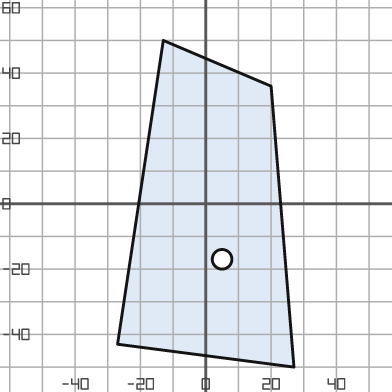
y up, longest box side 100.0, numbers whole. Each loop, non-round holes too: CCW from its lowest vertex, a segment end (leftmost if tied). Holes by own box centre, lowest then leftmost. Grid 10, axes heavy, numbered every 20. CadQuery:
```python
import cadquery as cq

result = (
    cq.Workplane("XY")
    .moveTo(27.0, -50.0)
    .lineTo(20.0, 36.0)
    .lineTo(-13.0, 50.0)
    .lineTo(-27.0, -43.0)
    .close()
    .moveTo(5.0, -17.0)
    .circle(3.0)
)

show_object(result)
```